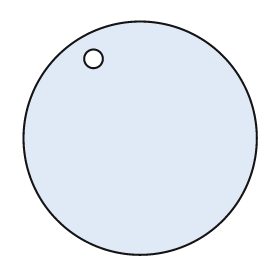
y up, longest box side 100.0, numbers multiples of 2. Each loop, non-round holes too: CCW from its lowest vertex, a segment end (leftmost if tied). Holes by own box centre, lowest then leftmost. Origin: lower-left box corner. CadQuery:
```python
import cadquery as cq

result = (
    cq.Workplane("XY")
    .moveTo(50.0, 50.0)
    .circle(50.0)
    .moveTo(30.0, 84.0)
    .circle(4.0)
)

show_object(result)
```